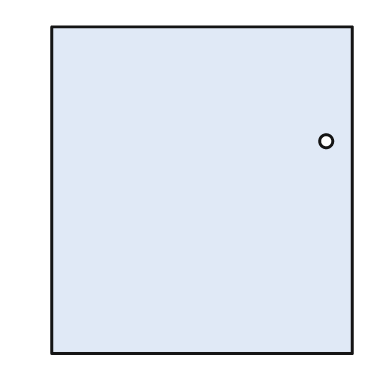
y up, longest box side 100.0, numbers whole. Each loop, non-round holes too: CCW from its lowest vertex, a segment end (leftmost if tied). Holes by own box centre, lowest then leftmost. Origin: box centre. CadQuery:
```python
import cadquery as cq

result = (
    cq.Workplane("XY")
    .moveTo(-46.0, -50.0)
    .lineTo(46.0, -50.0)
    .lineTo(46.0, 50.0)
    .lineTo(-46.0, 50.0)
    .close()
    .moveTo(38.0, 15.0)
    .circle(2.0)
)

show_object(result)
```